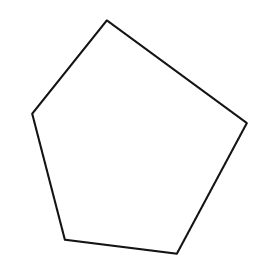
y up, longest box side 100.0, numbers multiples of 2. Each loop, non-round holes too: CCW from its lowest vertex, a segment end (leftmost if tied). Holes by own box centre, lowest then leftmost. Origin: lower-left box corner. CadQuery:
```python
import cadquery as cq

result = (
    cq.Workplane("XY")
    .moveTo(62.0, 0.0)
    .lineTo(92.0, 56.0)
    .lineTo(32.0, 100.0)
    .lineTo(0.0, 60.0)
    .lineTo(14.0, 6.0)
    .close()
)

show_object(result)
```